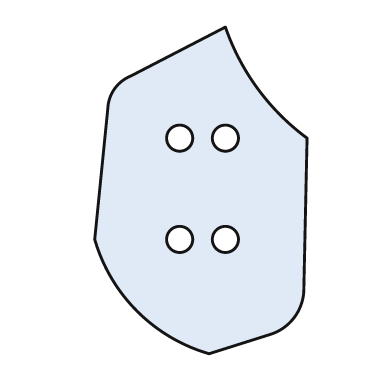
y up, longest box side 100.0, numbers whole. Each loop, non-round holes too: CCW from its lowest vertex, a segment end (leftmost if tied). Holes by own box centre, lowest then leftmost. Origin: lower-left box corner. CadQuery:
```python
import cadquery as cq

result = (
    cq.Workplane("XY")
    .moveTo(35.0, 0.0)
    .lineTo(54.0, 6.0)
    .threePointArc((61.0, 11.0), (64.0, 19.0))
    .lineTo(65.0, 66.0)
    .threePointArc((50.0, 81.0), (40.0, 100.0))
    .lineTo(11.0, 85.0)
    .threePointArc((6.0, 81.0), (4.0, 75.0))
    .lineTo(0.0, 35.0)
    .threePointArc((13.0, 13.0), (35.0, 0.0))
    .close()
    .moveTo(26.0, 35.0)
    .circle(4.0)
    .moveTo(40.0, 35.0)
    .circle(4.0)
    .moveTo(26.0, 66.0)
    .circle(4.0)
    .moveTo(40.0, 66.0)
    .circle(4.0)
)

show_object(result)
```